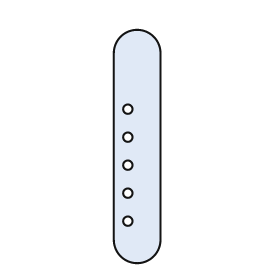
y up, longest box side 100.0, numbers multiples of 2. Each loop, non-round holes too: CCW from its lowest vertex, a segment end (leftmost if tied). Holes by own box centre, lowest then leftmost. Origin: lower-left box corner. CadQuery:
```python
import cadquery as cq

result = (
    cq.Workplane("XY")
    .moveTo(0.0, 10.0)
    .threePointArc((10.0, 0.0), (20.0, 10.0))
    .lineTo(20.0, 90.0)
    .threePointArc((10.0, 100.0), (0.0, 90.0))
    .close()
    .moveTo(6.0, 18.0)
    .circle(2.0)
    .moveTo(6.0, 30.0)
    .circle(2.0)
    .moveTo(6.0, 42.0)
    .circle(2.0)
    .moveTo(6.0, 54.0)
    .circle(2.0)
    .moveTo(6.0, 66.0)
    .circle(2.0)
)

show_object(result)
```